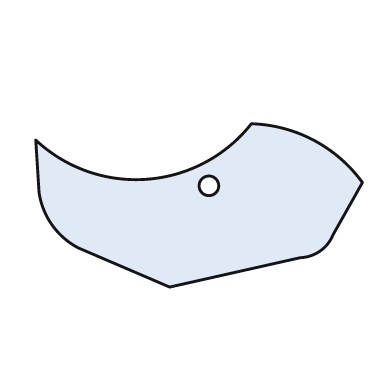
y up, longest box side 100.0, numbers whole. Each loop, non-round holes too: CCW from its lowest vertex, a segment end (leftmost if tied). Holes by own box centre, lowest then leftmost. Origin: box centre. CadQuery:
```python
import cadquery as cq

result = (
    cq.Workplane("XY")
    .moveTo(-9.0, -25.0)
    .lineTo(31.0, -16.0)
    .threePointArc((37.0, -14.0), (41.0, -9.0))
    .lineTo(50.0, 7.0)
    .threePointArc((35.0, 20.0), (16.0, 25.0))
    .threePointArc((-16.0, 8.0), (-50.0, 20.0))
    .lineTo(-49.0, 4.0)
    .threePointArc((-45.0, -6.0), (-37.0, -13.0))
    .close()
    .moveTo(3.0, 6.0)
    .circle(3.0)
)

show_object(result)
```